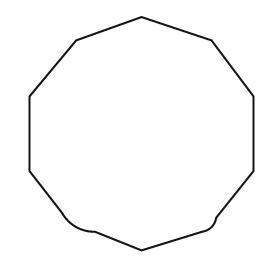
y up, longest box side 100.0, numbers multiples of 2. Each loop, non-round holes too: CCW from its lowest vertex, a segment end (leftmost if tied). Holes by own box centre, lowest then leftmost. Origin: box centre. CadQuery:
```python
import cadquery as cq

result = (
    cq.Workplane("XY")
    .moveTo(0.0, -50.0)
    .lineTo(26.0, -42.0)
    .threePointArc((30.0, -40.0), (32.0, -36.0))
    .lineTo(48.0, -16.0)
    .lineTo(48.0, 16.0)
    .lineTo(30.0, 40.0)
    .lineTo(0.0, 50.0)
    .lineTo(-28.0, 40.0)
    .lineTo(-48.0, 16.0)
    .lineTo(-48.0, -16.0)
    .lineTo(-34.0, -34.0)
    .threePointArc((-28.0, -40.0), (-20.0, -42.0))
    .close()
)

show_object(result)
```